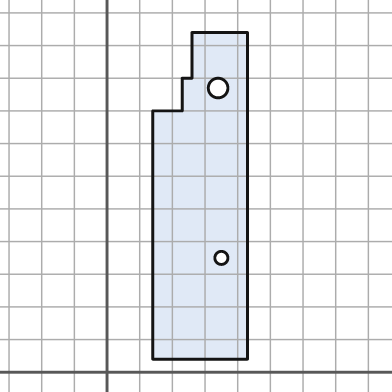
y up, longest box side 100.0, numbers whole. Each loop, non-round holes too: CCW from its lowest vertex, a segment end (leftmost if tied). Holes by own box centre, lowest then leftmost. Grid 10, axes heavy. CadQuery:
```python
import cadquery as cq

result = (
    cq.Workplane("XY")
    .moveTo(14.0, 4.0)
    .lineTo(43.0, 4.0)
    .lineTo(43.0, 104.0)
    .lineTo(26.0, 104.0)
    .lineTo(26.0, 90.0)
    .lineTo(23.0, 90.0)
    .lineTo(23.0, 80.0)
    .lineTo(14.0, 80.0)
    .close()
    .moveTo(35.0, 35.0)
    .circle(2.0)
    .moveTo(34.0, 87.0)
    .circle(3.0)
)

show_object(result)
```